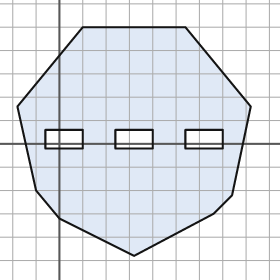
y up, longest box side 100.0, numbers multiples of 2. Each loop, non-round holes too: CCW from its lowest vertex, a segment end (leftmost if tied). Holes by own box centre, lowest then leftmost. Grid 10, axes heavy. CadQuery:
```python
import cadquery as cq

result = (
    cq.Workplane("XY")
    .moveTo(32.0, -48.0)
    .lineTo(66.0, -30.0)
    .lineTo(74.0, -22.0)
    .lineTo(82.0, 16.0)
    .lineTo(54.0, 50.0)
    .lineTo(10.0, 50.0)
    .lineTo(-18.0, 16.0)
    .lineTo(-10.0, -20.0)
    .lineTo(0.0, -32.0)
    .close()
    .moveTo(-6.0, -2.0)
    .lineTo(10.0, -2.0)
    .lineTo(10.0, 6.0)
    .lineTo(-6.0, 6.0)
    .close()
    .moveTo(24.0, -2.0)
    .lineTo(40.0, -2.0)
    .lineTo(40.0, 6.0)
    .lineTo(24.0, 6.0)
    .close()
    .moveTo(54.0, -2.0)
    .lineTo(70.0, -2.0)
    .lineTo(70.0, 6.0)
    .lineTo(54.0, 6.0)
    .close()
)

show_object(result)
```